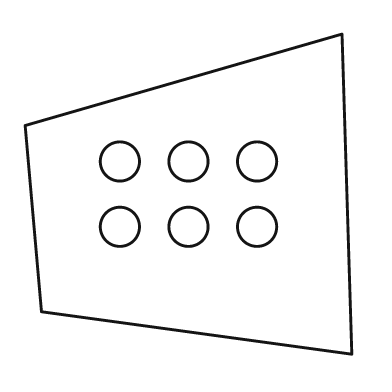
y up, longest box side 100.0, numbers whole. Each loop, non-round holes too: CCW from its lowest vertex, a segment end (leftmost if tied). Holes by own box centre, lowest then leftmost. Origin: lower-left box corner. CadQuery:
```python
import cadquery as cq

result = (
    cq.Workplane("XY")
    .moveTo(100.0, 0.0)
    .lineTo(97.0, 98.0)
    .lineTo(0.0, 70.0)
    .lineTo(5.0, 13.0)
    .close()
    .moveTo(29.0, 39.0)
    .circle(6.0)
    .moveTo(50.0, 39.0)
    .circle(6.0)
    .moveTo(71.0, 39.0)
    .circle(6.0)
    .moveTo(29.0, 59.0)
    .circle(6.0)
    .moveTo(50.0, 59.0)
    .circle(6.0)
    .moveTo(71.0, 59.0)
    .circle(6.0)
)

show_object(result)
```